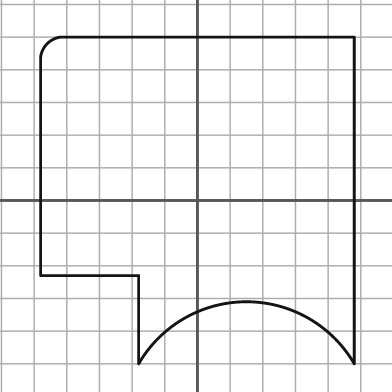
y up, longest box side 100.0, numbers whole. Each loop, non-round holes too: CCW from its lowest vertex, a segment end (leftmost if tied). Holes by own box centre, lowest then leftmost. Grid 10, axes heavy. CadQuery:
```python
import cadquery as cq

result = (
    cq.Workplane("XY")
    .moveTo(-18.0, -50.0)
    .threePointArc((15.0, -31.0), (48.0, -50.0))
    .lineTo(48.0, 50.0)
    .lineTo(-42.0, 50.0)
    .threePointArc((-46.0, 48.0), (-48.0, 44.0))
    .lineTo(-48.0, -23.0)
    .lineTo(-18.0, -23.0)
    .close()
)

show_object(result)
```